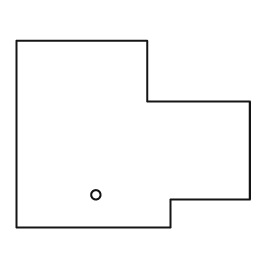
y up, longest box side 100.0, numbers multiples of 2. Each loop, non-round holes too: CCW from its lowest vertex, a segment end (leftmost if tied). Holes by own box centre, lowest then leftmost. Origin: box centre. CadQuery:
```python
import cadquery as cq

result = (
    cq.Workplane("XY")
    .moveTo(-50.0, -40.0)
    .lineTo(16.0, -40.0)
    .lineTo(16.0, -28.0)
    .lineTo(50.0, -28.0)
    .lineTo(50.0, 14.0)
    .lineTo(6.0, 14.0)
    .lineTo(6.0, 40.0)
    .lineTo(-50.0, 40.0)
    .close()
    .moveTo(-16.0, -26.0)
    .circle(2.0)
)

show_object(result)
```